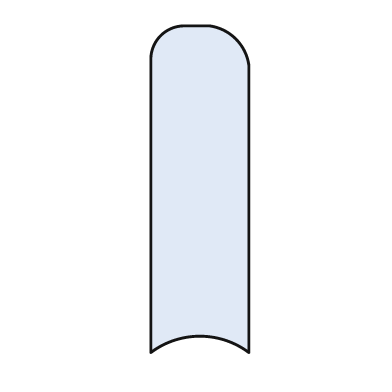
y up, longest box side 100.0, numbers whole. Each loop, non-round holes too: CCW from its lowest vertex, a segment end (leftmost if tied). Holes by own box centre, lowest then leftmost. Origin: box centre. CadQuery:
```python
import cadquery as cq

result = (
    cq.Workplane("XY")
    .moveTo(-15.0, -50.0)
    .threePointArc((0.0, -45.0), (15.0, -50.0))
    .lineTo(15.0, 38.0)
    .threePointArc((11.0, 46.0), (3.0, 50.0))
    .lineTo(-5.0, 50.0)
    .threePointArc((-12.0, 47.0), (-15.0, 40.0))
    .close()
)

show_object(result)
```